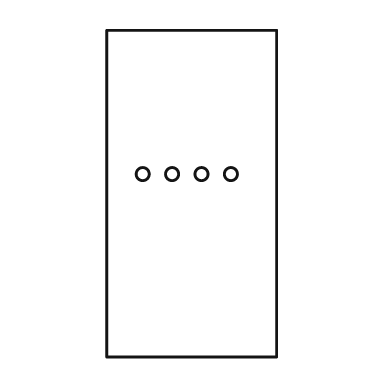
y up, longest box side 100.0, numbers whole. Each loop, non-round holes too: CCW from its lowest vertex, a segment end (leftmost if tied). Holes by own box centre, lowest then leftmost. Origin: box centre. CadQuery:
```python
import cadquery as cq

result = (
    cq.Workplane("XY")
    .moveTo(-26.0, -50.0)
    .lineTo(26.0, -50.0)
    .lineTo(26.0, 50.0)
    .lineTo(-26.0, 50.0)
    .close()
    .moveTo(-15.0, 6.0)
    .circle(2.0)
    .moveTo(-6.0, 6.0)
    .circle(2.0)
    .moveTo(3.0, 6.0)
    .circle(2.0)
    .moveTo(12.0, 6.0)
    .circle(2.0)
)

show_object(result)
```